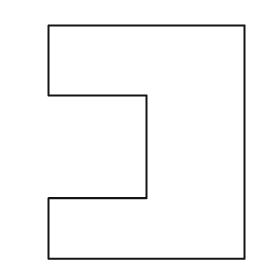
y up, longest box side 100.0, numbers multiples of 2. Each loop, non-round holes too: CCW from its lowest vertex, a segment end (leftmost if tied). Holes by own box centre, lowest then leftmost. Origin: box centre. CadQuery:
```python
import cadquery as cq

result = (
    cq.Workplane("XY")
    .moveTo(-42.0, -50.0)
    .lineTo(42.0, -50.0)
    .lineTo(42.0, 50.0)
    .lineTo(-42.0, 50.0)
    .lineTo(-42.0, 20.0)
    .lineTo(0.0, 20.0)
    .lineTo(0.0, -24.0)
    .lineTo(-42.0, -24.0)
    .close()
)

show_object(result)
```